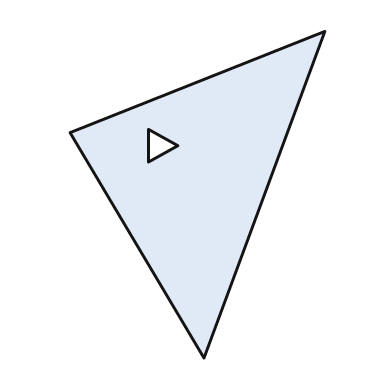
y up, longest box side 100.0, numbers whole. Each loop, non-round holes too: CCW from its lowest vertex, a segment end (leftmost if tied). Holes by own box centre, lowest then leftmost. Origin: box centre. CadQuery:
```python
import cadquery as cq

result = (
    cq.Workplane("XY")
    .moveTo(2.0, -50.0)
    .lineTo(39.0, 50.0)
    .lineTo(-39.0, 19.0)
    .close()
    .moveTo(-15.0, 10.0)
    .lineTo(-6.0, 15.0)
    .lineTo(-15.0, 20.0)
    .close()
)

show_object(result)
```